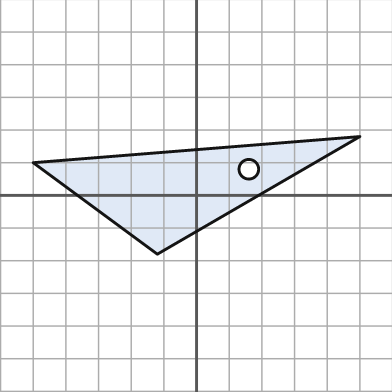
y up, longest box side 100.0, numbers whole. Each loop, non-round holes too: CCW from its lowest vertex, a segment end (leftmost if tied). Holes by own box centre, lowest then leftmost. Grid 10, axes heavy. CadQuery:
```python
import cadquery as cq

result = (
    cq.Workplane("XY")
    .moveTo(-12.0, -18.0)
    .lineTo(50.0, 18.0)
    .lineTo(-50.0, 10.0)
    .close()
    .moveTo(16.0, 8.0)
    .circle(3.0)
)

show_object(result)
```